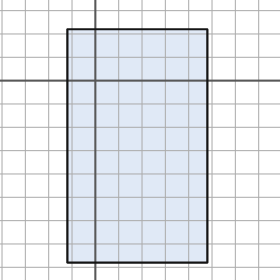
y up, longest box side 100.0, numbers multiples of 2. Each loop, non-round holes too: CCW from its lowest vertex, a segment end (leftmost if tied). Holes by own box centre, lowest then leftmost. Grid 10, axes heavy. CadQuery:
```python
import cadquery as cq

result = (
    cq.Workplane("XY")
    .moveTo(-12.0, -78.0)
    .lineTo(48.0, -78.0)
    .lineTo(48.0, 22.0)
    .lineTo(-12.0, 22.0)
    .close()
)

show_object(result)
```